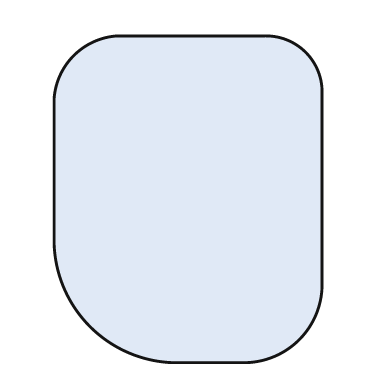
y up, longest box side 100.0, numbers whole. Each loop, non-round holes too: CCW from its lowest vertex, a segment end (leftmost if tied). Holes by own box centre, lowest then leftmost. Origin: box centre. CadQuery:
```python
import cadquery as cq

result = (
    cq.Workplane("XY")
    .moveTo(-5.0, -50.0)
    .lineTo(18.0, -50.0)
    .threePointArc((34.0, -43.0), (41.0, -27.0))
    .lineTo(41.0, 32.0)
    .threePointArc((36.0, 45.0), (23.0, 50.0))
    .lineTo(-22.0, 50.0)
    .threePointArc((-35.0, 44.0), (-41.0, 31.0))
    .lineTo(-41.0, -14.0)
    .threePointArc((-30.0, -39.0), (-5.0, -50.0))
    .close()
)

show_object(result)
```